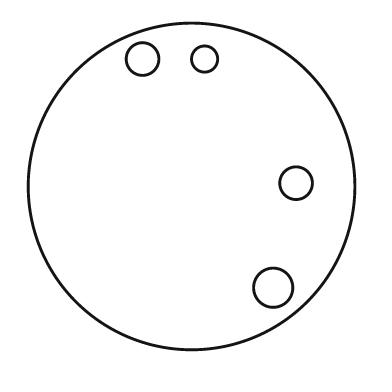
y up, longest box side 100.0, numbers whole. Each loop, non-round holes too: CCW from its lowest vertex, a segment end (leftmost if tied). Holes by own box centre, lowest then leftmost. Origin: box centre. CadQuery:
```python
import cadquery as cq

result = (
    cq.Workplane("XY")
    .moveTo(0.0, 0.0)
    .circle(50.0)
    .moveTo(25.0, -31.0)
    .circle(6.0)
    .moveTo(32.0, 1.0)
    .circle(5.0)
    .moveTo(-15.0, 39.0)
    .circle(5.0)
    .moveTo(4.0, 39.0)
    .circle(4.0)
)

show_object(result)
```